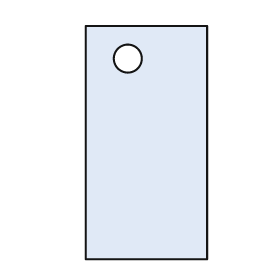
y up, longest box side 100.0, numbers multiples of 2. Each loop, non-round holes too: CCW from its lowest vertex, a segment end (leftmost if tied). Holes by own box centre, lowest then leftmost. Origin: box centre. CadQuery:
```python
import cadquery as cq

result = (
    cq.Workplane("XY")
    .moveTo(-26.0, -50.0)
    .lineTo(26.0, -50.0)
    .lineTo(26.0, 50.0)
    .lineTo(-26.0, 50.0)
    .close()
    .moveTo(-8.0, 36.0)
    .circle(6.0)
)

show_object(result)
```